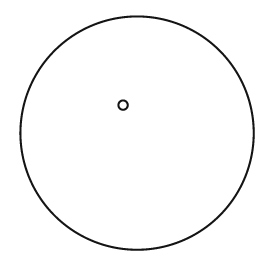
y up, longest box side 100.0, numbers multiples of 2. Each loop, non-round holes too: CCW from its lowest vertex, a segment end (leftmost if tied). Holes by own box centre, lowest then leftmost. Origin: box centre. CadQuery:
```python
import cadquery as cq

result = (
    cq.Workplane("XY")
    .moveTo(0.0, 0.0)
    .circle(50.0)
    .moveTo(-6.0, 12.0)
    .circle(2.0)
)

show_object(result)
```